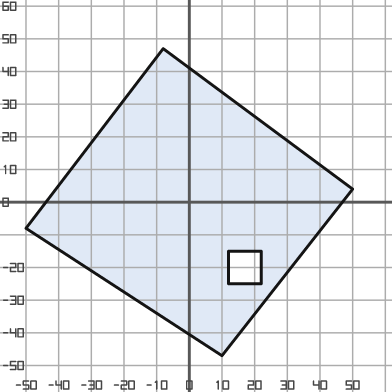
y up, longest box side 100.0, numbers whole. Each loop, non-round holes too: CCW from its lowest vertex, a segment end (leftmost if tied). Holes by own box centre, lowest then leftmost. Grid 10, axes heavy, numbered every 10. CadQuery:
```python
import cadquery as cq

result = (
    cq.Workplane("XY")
    .moveTo(10.0, -47.0)
    .lineTo(50.0, 4.0)
    .lineTo(-8.0, 47.0)
    .lineTo(-50.0, -8.0)
    .close()
    .moveTo(12.0, -25.0)
    .lineTo(22.0, -25.0)
    .lineTo(22.0, -15.0)
    .lineTo(12.0, -15.0)
    .close()
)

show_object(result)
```